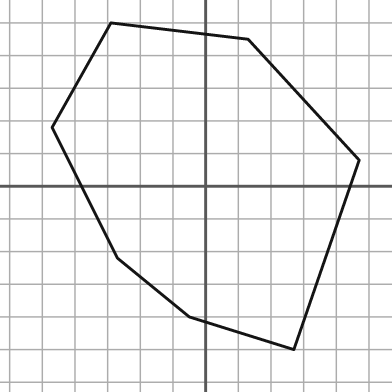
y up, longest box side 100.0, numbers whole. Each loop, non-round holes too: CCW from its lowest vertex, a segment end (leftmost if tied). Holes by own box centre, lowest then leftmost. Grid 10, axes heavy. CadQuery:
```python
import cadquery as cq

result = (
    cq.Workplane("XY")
    .moveTo(27.0, -50.0)
    .lineTo(47.0, 8.0)
    .lineTo(13.0, 45.0)
    .lineTo(-29.0, 50.0)
    .lineTo(-47.0, 18.0)
    .lineTo(-27.0, -22.0)
    .lineTo(-5.0, -40.0)
    .close()
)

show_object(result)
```